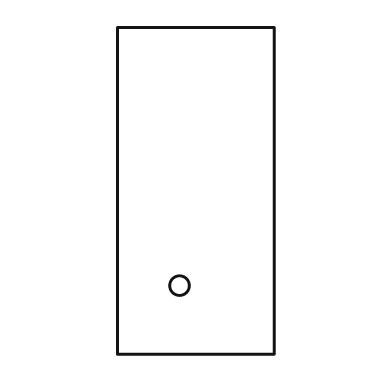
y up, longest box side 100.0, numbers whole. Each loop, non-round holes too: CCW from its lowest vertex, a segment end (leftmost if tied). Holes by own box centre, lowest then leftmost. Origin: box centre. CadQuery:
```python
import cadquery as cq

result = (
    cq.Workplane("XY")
    .moveTo(-24.0, -50.0)
    .lineTo(24.0, -50.0)
    .lineTo(24.0, 50.0)
    .lineTo(-24.0, 50.0)
    .close()
    .moveTo(-5.0, -29.0)
    .circle(3.0)
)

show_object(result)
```